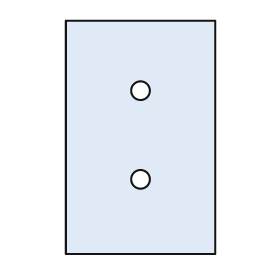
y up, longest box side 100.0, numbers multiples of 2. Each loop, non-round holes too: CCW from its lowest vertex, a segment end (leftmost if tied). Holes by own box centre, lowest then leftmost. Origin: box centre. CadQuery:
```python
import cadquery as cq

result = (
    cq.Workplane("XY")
    .moveTo(-32.0, -50.0)
    .lineTo(32.0, -50.0)
    .lineTo(32.0, 50.0)
    .lineTo(-32.0, 50.0)
    .close()
    .moveTo(0.0, -18.0)
    .circle(4.0)
    .moveTo(0.0, 20.0)
    .circle(4.0)
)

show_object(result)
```